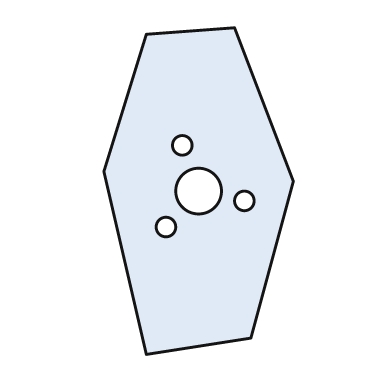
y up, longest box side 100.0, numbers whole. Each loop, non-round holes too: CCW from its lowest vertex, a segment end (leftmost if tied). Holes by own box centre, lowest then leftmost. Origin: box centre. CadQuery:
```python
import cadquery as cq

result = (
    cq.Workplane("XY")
    .moveTo(-16.0, -50.0)
    .lineTo(16.0, -45.0)
    .lineTo(29.0, 3.0)
    .lineTo(11.0, 50.0)
    .lineTo(-16.0, 48.0)
    .lineTo(-29.0, 6.0)
    .close()
    .moveTo(-10.0, -11.0)
    .circle(3.0)
    .moveTo(14.0, -3.0)
    .circle(3.0)
    .moveTo(0.0, 0.0)
    .circle(7.0)
    .moveTo(-5.0, 14.0)
    .circle(3.0)
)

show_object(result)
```